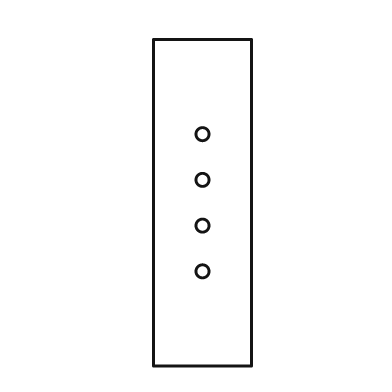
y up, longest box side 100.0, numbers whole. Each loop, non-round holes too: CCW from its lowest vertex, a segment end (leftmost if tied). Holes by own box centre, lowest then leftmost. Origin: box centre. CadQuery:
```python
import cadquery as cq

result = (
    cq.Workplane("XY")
    .moveTo(-15.0, -50.0)
    .lineTo(15.0, -50.0)
    .lineTo(15.0, 50.0)
    .lineTo(-15.0, 50.0)
    .close()
    .moveTo(0.0, -21.0)
    .circle(2.0)
    .moveTo(0.0, -7.0)
    .circle(2.0)
    .moveTo(0.0, 7.0)
    .circle(2.0)
    .moveTo(0.0, 21.0)
    .circle(2.0)
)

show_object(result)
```